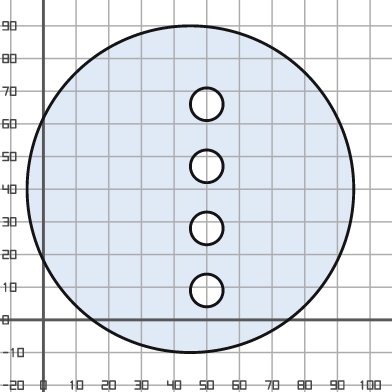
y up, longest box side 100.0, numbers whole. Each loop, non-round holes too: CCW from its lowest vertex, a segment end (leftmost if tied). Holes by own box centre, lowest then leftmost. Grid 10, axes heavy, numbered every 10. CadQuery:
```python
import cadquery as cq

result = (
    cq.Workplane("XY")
    .moveTo(45.0, 40.0)
    .circle(50.0)
    .moveTo(50.0, 9.0)
    .circle(5.0)
    .moveTo(50.0, 28.0)
    .circle(5.0)
    .moveTo(50.0, 47.0)
    .circle(5.0)
    .moveTo(50.0, 66.0)
    .circle(5.0)
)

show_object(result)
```